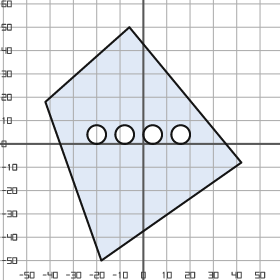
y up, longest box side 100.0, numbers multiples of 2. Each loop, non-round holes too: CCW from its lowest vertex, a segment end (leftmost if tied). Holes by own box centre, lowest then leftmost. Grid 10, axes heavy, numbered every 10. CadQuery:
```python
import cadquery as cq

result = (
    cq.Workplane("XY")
    .moveTo(-18.0, -50.0)
    .lineTo(42.0, -8.0)
    .lineTo(-6.0, 50.0)
    .lineTo(-42.0, 18.0)
    .close()
    .moveTo(-20.0, 4.0)
    .circle(4.0)
    .moveTo(-8.0, 4.0)
    .circle(4.0)
    .moveTo(4.0, 4.0)
    .circle(4.0)
    .moveTo(16.0, 4.0)
    .circle(4.0)
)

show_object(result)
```